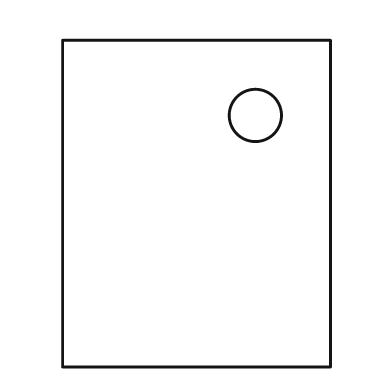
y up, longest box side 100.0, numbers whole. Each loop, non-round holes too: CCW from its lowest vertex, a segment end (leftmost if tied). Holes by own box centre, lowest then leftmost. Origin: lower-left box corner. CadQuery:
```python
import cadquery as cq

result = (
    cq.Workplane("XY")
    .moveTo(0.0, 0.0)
    .lineTo(82.0, 0.0)
    .lineTo(82.0, 100.0)
    .lineTo(0.0, 100.0)
    .close()
    .moveTo(59.0, 77.0)
    .circle(8.0)
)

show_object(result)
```